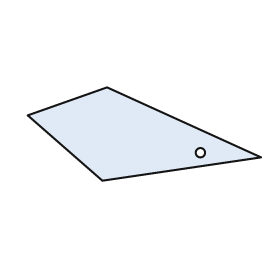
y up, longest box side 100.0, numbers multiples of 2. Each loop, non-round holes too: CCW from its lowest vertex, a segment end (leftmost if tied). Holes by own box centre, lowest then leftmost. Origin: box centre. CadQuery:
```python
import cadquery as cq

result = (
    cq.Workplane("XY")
    .moveTo(-18.0, -20.0)
    .lineTo(50.0, -10.0)
    .lineTo(-16.0, 20.0)
    .lineTo(-50.0, 8.0)
    .close()
    .moveTo(24.0, -8.0)
    .circle(2.0)
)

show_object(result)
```